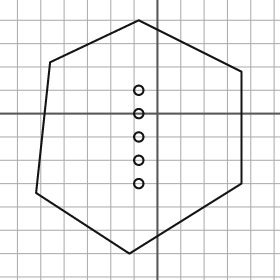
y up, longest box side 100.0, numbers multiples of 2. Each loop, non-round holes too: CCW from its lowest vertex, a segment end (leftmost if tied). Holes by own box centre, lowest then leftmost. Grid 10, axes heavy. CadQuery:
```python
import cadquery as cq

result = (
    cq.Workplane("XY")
    .moveTo(-12.0, -60.0)
    .lineTo(36.0, -30.0)
    .lineTo(36.0, 18.0)
    .lineTo(-8.0, 40.0)
    .lineTo(-46.0, 22.0)
    .lineTo(-52.0, -34.0)
    .close()
    .moveTo(-8.0, -30.0)
    .circle(2.0)
    .moveTo(-8.0, -20.0)
    .circle(2.0)
    .moveTo(-8.0, -10.0)
    .circle(2.0)
    .moveTo(-8.0, 0.0)
    .circle(2.0)
    .moveTo(-8.0, 10.0)
    .circle(2.0)
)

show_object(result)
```